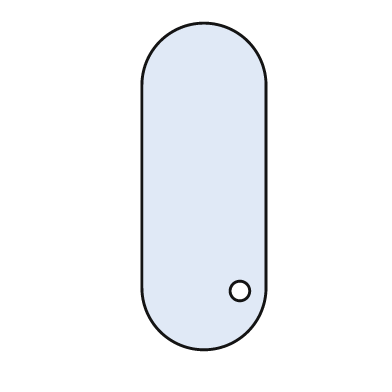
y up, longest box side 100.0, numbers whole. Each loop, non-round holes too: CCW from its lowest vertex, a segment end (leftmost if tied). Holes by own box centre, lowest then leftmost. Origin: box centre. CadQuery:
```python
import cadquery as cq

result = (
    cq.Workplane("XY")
    .moveTo(-19.0, -31.0)
    .threePointArc((0.0, -50.0), (19.0, -31.0))
    .lineTo(19.0, 31.0)
    .threePointArc((0.0, 50.0), (-19.0, 31.0))
    .close()
    .moveTo(11.0, -32.0)
    .circle(3.0)
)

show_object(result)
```